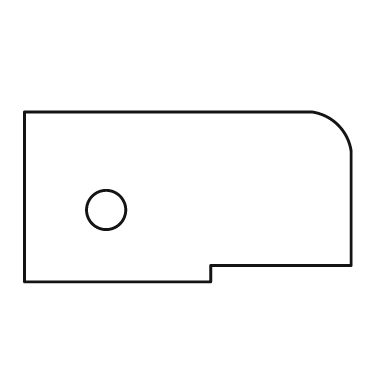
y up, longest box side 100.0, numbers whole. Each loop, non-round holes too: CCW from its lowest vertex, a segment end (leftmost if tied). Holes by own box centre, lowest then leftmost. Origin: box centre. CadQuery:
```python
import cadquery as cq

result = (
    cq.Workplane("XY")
    .moveTo(-50.0, -26.0)
    .lineTo(7.0, -26.0)
    .lineTo(7.0, -21.0)
    .lineTo(50.0, -21.0)
    .lineTo(50.0, 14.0)
    .threePointArc((46.0, 22.0), (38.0, 26.0))
    .lineTo(-50.0, 26.0)
    .close()
    .moveTo(-25.0, -4.0)
    .circle(6.0)
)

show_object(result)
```